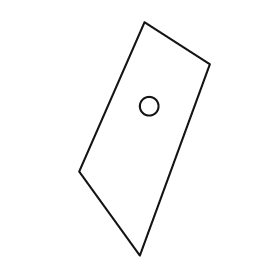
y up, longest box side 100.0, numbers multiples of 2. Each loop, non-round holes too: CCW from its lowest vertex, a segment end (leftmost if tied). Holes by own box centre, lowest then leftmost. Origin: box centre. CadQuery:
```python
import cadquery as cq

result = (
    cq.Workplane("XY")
    .moveTo(-2.0, -50.0)
    .lineTo(28.0, 32.0)
    .lineTo(0.0, 50.0)
    .lineTo(-28.0, -14.0)
    .close()
    .moveTo(2.0, 14.0)
    .circle(4.0)
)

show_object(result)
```